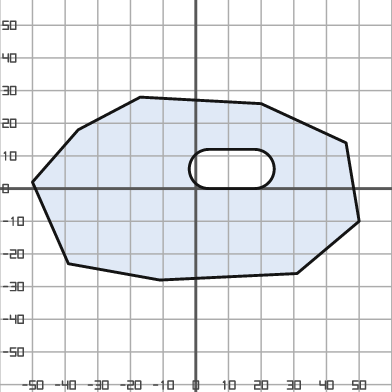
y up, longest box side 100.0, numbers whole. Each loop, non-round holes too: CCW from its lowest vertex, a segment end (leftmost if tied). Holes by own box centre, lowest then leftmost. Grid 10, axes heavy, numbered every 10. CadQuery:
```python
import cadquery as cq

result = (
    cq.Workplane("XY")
    .moveTo(-11.0, -28.0)
    .lineTo(31.0, -26.0)
    .lineTo(50.0, -10.0)
    .lineTo(46.0, 14.0)
    .lineTo(20.0, 26.0)
    .lineTo(-17.0, 28.0)
    .lineTo(-36.0, 18.0)
    .lineTo(-50.0, 2.0)
    .lineTo(-39.0, -23.0)
    .close()
    .moveTo(4.0, 0.0)
    .lineTo(18.0, 0.0)
    .threePointArc((24.0, 6.0), (18.0, 12.0))
    .lineTo(4.0, 12.0)
    .threePointArc((-2.0, 6.0), (4.0, 0.0))
    .close()
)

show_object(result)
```